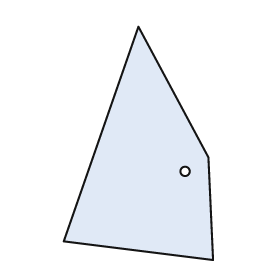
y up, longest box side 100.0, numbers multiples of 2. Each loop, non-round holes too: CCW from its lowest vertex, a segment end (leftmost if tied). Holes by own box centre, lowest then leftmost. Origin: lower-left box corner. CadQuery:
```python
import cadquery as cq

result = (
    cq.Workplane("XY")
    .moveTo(64.0, 0.0)
    .lineTo(62.0, 44.0)
    .lineTo(32.0, 100.0)
    .lineTo(0.0, 8.0)
    .close()
    .moveTo(52.0, 38.0)
    .circle(2.0)
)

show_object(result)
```